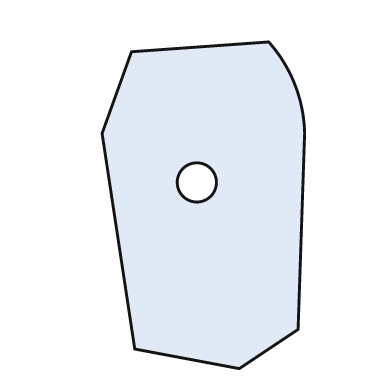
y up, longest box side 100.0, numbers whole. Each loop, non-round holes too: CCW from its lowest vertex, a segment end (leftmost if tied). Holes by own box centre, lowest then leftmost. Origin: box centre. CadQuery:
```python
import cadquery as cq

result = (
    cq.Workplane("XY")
    .moveTo(11.0, -50.0)
    .lineTo(29.0, -38.0)
    .lineTo(31.0, 22.0)
    .threePointArc((28.0, 37.0), (20.0, 50.0))
    .lineTo(-22.0, 47.0)
    .lineTo(-31.0, 22.0)
    .lineTo(-21.0, -44.0)
    .close()
    .moveTo(-2.0, 7.0)
    .circle(6.0)
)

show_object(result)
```